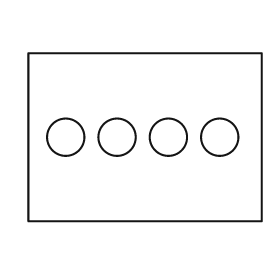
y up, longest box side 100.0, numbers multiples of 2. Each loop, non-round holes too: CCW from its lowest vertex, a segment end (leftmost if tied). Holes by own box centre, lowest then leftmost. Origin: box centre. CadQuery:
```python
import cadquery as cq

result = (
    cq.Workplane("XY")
    .moveTo(-50.0, -36.0)
    .lineTo(50.0, -36.0)
    .lineTo(50.0, 36.0)
    .lineTo(-50.0, 36.0)
    .close()
    .moveTo(-34.0, 0.0)
    .circle(8.0)
    .moveTo(-12.0, 0.0)
    .circle(8.0)
    .moveTo(10.0, 0.0)
    .circle(8.0)
    .moveTo(32.0, 0.0)
    .circle(8.0)
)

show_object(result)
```